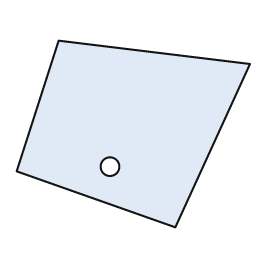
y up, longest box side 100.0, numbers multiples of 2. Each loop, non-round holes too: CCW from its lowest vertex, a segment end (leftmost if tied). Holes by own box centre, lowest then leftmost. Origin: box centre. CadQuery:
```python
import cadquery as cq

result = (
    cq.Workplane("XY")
    .moveTo(18.0, -40.0)
    .lineTo(50.0, 30.0)
    .lineTo(-32.0, 40.0)
    .lineTo(-50.0, -16.0)
    .close()
    .moveTo(-10.0, -14.0)
    .circle(4.0)
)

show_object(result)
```